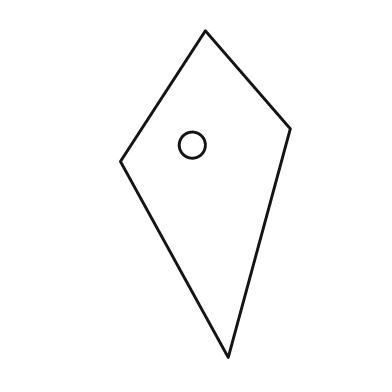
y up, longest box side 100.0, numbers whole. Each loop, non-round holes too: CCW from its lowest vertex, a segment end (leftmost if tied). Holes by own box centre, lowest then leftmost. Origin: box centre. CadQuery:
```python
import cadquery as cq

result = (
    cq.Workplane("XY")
    .moveTo(7.0, -50.0)
    .lineTo(26.0, 20.0)
    .lineTo(0.0, 50.0)
    .lineTo(-26.0, 10.0)
    .close()
    .moveTo(-4.0, 15.0)
    .circle(4.0)
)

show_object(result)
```